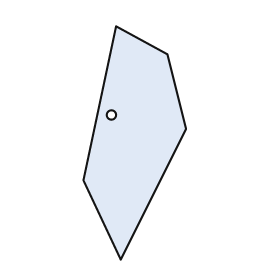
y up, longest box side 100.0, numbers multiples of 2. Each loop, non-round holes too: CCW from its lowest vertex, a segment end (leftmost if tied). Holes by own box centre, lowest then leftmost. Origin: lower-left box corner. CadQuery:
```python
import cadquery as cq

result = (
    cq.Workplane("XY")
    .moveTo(16.0, 0.0)
    .lineTo(44.0, 56.0)
    .lineTo(36.0, 88.0)
    .lineTo(14.0, 100.0)
    .lineTo(0.0, 34.0)
    .close()
    .moveTo(12.0, 62.0)
    .circle(2.0)
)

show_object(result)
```